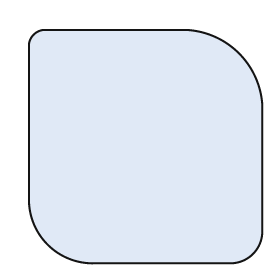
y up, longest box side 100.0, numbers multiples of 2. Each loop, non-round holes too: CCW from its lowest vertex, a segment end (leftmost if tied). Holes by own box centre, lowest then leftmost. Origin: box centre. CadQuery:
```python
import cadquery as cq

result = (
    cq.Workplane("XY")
    .moveTo(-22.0, -50.0)
    .lineTo(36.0, -50.0)
    .threePointArc((46.0, -46.0), (50.0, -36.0))
    .lineTo(50.0, 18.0)
    .threePointArc((40.0, 40.0), (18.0, 50.0))
    .lineTo(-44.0, 50.0)
    .threePointArc((-48.0, 48.0), (-50.0, 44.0))
    .lineTo(-50.0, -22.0)
    .threePointArc((-42.0, -42.0), (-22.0, -50.0))
    .close()
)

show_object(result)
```